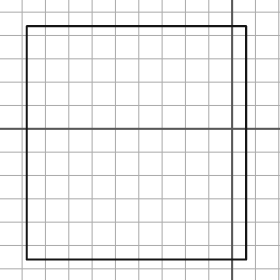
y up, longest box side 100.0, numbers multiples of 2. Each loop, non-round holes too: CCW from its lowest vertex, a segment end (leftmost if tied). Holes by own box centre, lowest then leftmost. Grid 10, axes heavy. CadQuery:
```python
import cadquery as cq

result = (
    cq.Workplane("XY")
    .moveTo(-88.0, -56.0)
    .lineTo(6.0, -56.0)
    .lineTo(6.0, 44.0)
    .lineTo(-88.0, 44.0)
    .close()
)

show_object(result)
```